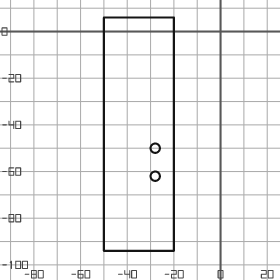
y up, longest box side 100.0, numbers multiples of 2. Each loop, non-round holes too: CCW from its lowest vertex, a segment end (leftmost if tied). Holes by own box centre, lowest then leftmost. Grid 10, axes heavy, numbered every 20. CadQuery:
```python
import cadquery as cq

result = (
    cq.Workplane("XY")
    .moveTo(-50.0, -94.0)
    .lineTo(-20.0, -94.0)
    .lineTo(-20.0, 6.0)
    .lineTo(-50.0, 6.0)
    .close()
    .moveTo(-28.0, -62.0)
    .circle(2.0)
    .moveTo(-28.0, -50.0)
    .circle(2.0)
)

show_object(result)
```